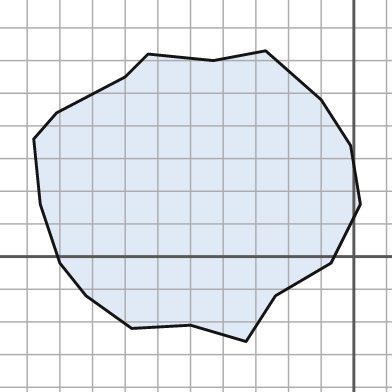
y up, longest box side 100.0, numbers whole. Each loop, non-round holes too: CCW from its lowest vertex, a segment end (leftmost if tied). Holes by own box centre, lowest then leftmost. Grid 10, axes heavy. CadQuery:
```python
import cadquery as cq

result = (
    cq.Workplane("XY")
    .moveTo(-33.0, -26.0)
    .lineTo(-24.0, -12.0)
    .lineTo(-7.0, -2.0)
    .lineTo(2.0, 16.0)
    .lineTo(-1.0, 34.0)
    .lineTo(-10.0, 48.0)
    .lineTo(-27.0, 63.0)
    .lineTo(-43.0, 60.0)
    .lineTo(-63.0, 62.0)
    .lineTo(-70.0, 55.0)
    .lineTo(-91.0, 44.0)
    .lineTo(-98.0, 36.0)
    .lineTo(-96.0, 16.0)
    .lineTo(-90.0, -2.0)
    .lineTo(-82.0, -12.0)
    .lineTo(-68.0, -22.0)
    .lineTo(-50.0, -21.0)
    .close()
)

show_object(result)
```